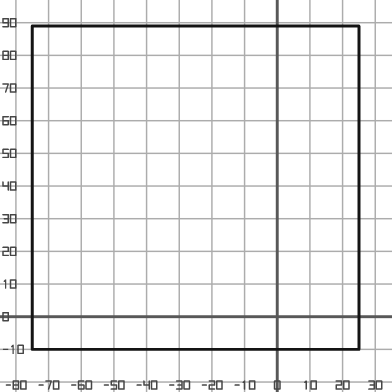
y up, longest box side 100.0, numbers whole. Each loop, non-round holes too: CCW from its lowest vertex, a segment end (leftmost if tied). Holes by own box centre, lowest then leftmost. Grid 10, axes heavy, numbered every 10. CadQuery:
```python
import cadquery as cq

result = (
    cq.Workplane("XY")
    .moveTo(-75.0, -10.0)
    .lineTo(25.0, -10.0)
    .lineTo(25.0, 89.0)
    .lineTo(-75.0, 89.0)
    .close()
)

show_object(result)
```